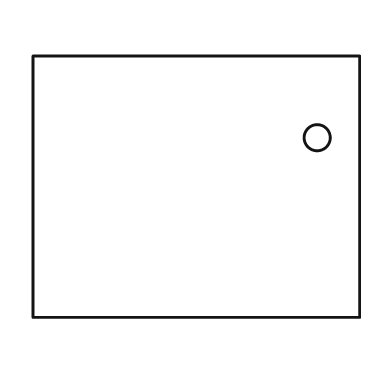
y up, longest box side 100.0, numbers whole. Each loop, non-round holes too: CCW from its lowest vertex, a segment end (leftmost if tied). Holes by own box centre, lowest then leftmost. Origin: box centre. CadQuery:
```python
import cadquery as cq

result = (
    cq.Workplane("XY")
    .moveTo(-50.0, -40.0)
    .lineTo(50.0, -40.0)
    .lineTo(50.0, 40.0)
    .lineTo(-50.0, 40.0)
    .close()
    .moveTo(37.0, 15.0)
    .circle(4.0)
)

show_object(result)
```